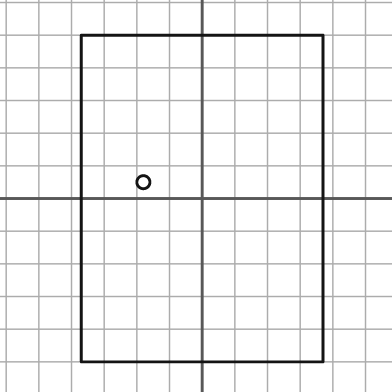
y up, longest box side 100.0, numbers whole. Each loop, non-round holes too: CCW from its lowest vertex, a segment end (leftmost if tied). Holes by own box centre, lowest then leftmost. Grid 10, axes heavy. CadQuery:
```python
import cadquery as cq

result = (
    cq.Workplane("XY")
    .moveTo(-37.0, -50.0)
    .lineTo(37.0, -50.0)
    .lineTo(37.0, 50.0)
    .lineTo(-37.0, 50.0)
    .close()
    .moveTo(-18.0, 5.0)
    .circle(2.0)
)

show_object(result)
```